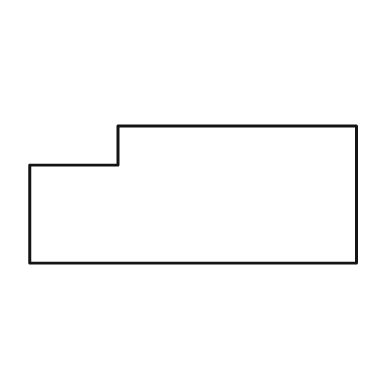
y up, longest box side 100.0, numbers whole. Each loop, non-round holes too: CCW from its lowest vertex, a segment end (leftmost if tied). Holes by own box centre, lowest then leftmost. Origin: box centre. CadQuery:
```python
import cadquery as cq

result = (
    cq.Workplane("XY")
    .moveTo(-50.0, -21.0)
    .lineTo(50.0, -21.0)
    .lineTo(50.0, 21.0)
    .lineTo(-23.0, 21.0)
    .lineTo(-23.0, 9.0)
    .lineTo(-50.0, 9.0)
    .close()
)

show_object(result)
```